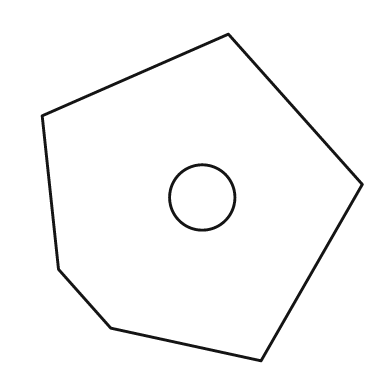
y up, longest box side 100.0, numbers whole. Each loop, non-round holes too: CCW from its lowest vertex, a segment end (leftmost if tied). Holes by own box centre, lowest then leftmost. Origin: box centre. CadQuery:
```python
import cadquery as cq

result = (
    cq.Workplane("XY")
    .moveTo(18.0, -50.0)
    .lineTo(49.0, 4.0)
    .lineTo(8.0, 50.0)
    .lineTo(-49.0, 25.0)
    .lineTo(-44.0, -22.0)
    .lineTo(-28.0, -40.0)
    .close()
    .moveTo(0.0, 0.0)
    .circle(10.0)
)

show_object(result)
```